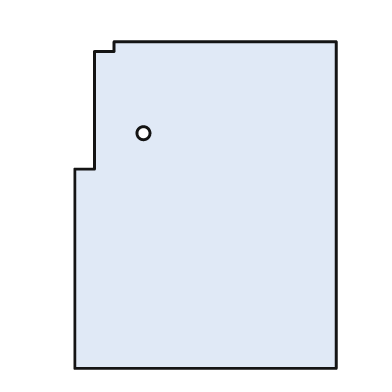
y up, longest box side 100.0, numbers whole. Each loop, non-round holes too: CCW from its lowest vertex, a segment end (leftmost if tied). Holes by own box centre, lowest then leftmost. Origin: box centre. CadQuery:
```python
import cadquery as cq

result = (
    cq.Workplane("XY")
    .moveTo(-40.0, -50.0)
    .lineTo(40.0, -50.0)
    .lineTo(40.0, 50.0)
    .lineTo(-28.0, 50.0)
    .lineTo(-28.0, 47.0)
    .lineTo(-34.0, 47.0)
    .lineTo(-34.0, 11.0)
    .lineTo(-40.0, 11.0)
    .close()
    .moveTo(-19.0, 22.0)
    .circle(2.0)
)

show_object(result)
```